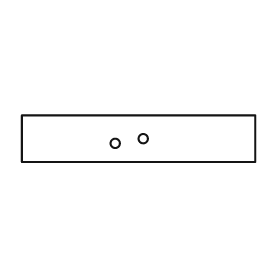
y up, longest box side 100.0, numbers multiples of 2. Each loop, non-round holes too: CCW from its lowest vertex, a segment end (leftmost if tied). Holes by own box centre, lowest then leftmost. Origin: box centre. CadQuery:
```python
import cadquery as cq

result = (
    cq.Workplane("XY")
    .moveTo(-50.0, -10.0)
    .lineTo(50.0, -10.0)
    .lineTo(50.0, 10.0)
    .lineTo(-50.0, 10.0)
    .close()
    .moveTo(-10.0, -2.0)
    .circle(2.0)
    .moveTo(2.0, 0.0)
    .circle(2.0)
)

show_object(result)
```